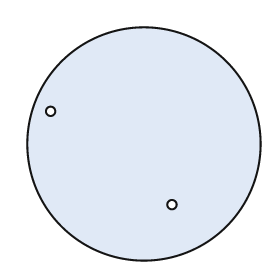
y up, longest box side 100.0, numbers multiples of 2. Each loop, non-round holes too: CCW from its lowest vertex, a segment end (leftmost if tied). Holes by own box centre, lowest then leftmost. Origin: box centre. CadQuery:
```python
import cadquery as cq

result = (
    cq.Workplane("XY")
    .moveTo(0.0, 0.0)
    .circle(50.0)
    .moveTo(12.0, -26.0)
    .circle(2.0)
    .moveTo(-40.0, 14.0)
    .circle(2.0)
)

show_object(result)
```